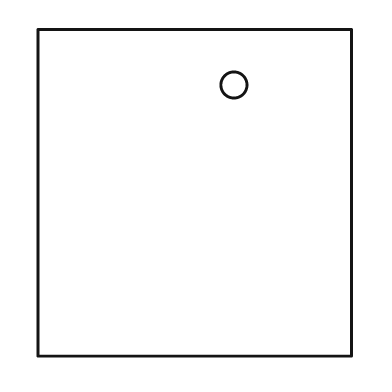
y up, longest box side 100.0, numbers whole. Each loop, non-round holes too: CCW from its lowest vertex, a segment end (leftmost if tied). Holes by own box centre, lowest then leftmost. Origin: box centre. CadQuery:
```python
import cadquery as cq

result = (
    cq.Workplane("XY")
    .moveTo(-48.0, -50.0)
    .lineTo(48.0, -50.0)
    .lineTo(48.0, 50.0)
    .lineTo(-48.0, 50.0)
    .close()
    .moveTo(12.0, 33.0)
    .circle(4.0)
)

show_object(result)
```